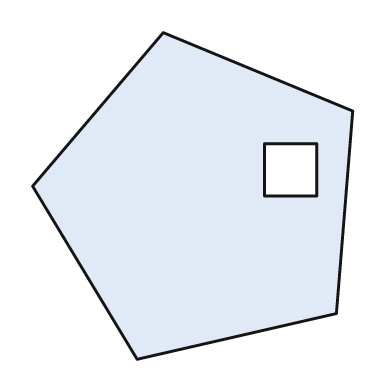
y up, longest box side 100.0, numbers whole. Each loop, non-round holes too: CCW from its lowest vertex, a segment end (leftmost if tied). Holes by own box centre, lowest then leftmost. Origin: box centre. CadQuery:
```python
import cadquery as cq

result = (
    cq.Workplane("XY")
    .moveTo(-17.0, -50.0)
    .lineTo(44.0, -36.0)
    .lineTo(49.0, 26.0)
    .lineTo(-9.0, 50.0)
    .lineTo(-49.0, 3.0)
    .close()
    .moveTo(22.0, 0.0)
    .lineTo(38.0, 0.0)
    .lineTo(38.0, 16.0)
    .lineTo(22.0, 16.0)
    .close()
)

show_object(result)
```